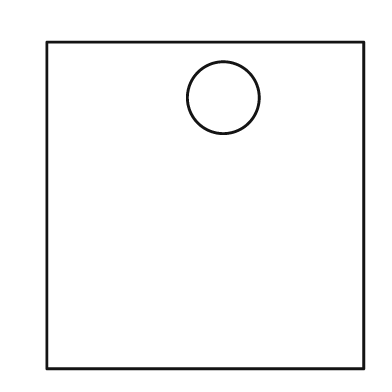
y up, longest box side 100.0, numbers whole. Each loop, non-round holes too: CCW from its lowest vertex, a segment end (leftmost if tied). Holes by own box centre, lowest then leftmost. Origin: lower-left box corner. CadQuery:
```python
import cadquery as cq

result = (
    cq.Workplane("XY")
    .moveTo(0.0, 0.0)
    .lineTo(97.0, 0.0)
    .lineTo(97.0, 100.0)
    .lineTo(0.0, 100.0)
    .close()
    .moveTo(54.0, 83.0)
    .circle(11.0)
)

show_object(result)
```